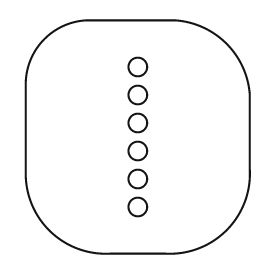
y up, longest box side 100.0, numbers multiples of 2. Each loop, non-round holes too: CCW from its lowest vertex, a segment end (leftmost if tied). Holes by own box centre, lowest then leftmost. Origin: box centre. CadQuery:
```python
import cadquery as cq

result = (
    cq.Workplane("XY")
    .moveTo(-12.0, -50.0)
    .lineTo(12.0, -50.0)
    .threePointArc((38.0, -40.0), (48.0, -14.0))
    .lineTo(48.0, 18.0)
    .threePointArc((38.0, 40.0), (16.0, 50.0))
    .lineTo(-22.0, 50.0)
    .threePointArc((-40.0, 42.0), (-48.0, 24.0))
    .lineTo(-48.0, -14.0)
    .threePointArc((-38.0, -40.0), (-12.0, -50.0))
    .close()
    .moveTo(0.0, -30.0)
    .circle(4.0)
    .moveTo(0.0, -18.0)
    .circle(4.0)
    .moveTo(0.0, -6.0)
    .circle(4.0)
    .moveTo(0.0, 6.0)
    .circle(4.0)
    .moveTo(0.0, 18.0)
    .circle(4.0)
    .moveTo(0.0, 30.0)
    .circle(4.0)
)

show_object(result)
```